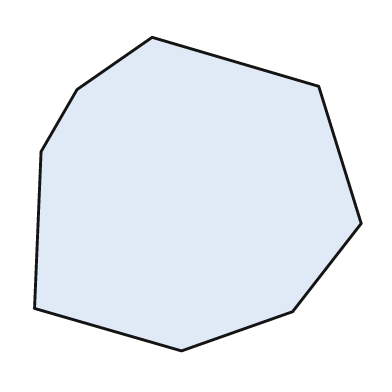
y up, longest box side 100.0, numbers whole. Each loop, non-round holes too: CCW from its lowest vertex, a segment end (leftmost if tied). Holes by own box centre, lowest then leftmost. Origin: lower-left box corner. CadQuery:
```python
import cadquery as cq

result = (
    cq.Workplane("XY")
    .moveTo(45.0, 0.0)
    .lineTo(79.0, 12.0)
    .lineTo(100.0, 39.0)
    .lineTo(87.0, 81.0)
    .lineTo(36.0, 96.0)
    .lineTo(13.0, 80.0)
    .lineTo(2.0, 61.0)
    .lineTo(0.0, 13.0)
    .close()
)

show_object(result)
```